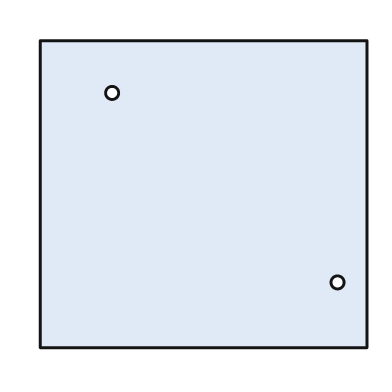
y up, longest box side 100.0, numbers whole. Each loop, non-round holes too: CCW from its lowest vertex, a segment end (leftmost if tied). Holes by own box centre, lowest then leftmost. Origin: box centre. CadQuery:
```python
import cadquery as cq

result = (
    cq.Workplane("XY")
    .moveTo(-50.0, -47.0)
    .lineTo(50.0, -47.0)
    .lineTo(50.0, 47.0)
    .lineTo(-50.0, 47.0)
    .close()
    .moveTo(41.0, -27.0)
    .circle(2.0)
    .moveTo(-28.0, 31.0)
    .circle(2.0)
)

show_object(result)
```